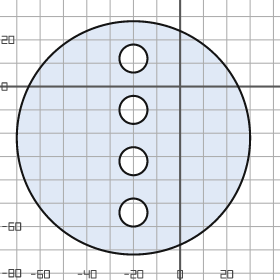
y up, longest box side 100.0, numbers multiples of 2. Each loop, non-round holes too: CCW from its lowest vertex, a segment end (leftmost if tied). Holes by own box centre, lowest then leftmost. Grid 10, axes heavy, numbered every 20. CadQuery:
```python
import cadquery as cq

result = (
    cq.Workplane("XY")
    .moveTo(-20.0, -22.0)
    .circle(50.0)
    .moveTo(-20.0, -54.0)
    .circle(6.0)
    .moveTo(-20.0, -32.0)
    .circle(6.0)
    .moveTo(-20.0, -10.0)
    .circle(6.0)
    .moveTo(-20.0, 12.0)
    .circle(6.0)
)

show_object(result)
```